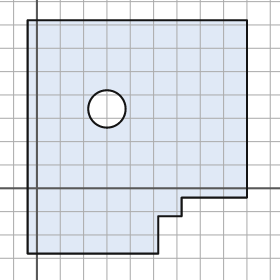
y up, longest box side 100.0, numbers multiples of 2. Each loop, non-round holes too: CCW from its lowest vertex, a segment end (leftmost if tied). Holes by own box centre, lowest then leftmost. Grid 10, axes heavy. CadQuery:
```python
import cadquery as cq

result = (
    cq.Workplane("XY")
    .moveTo(-4.0, -28.0)
    .lineTo(52.0, -28.0)
    .lineTo(52.0, -12.0)
    .lineTo(62.0, -12.0)
    .lineTo(62.0, -4.0)
    .lineTo(90.0, -4.0)
    .lineTo(90.0, 72.0)
    .lineTo(-4.0, 72.0)
    .close()
    .moveTo(30.0, 34.0)
    .circle(8.0)
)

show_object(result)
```